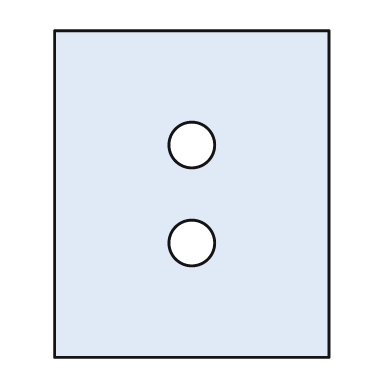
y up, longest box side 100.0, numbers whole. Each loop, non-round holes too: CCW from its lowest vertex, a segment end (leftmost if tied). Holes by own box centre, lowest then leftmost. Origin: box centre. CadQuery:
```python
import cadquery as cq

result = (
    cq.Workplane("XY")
    .moveTo(-42.0, -50.0)
    .lineTo(42.0, -50.0)
    .lineTo(42.0, 50.0)
    .lineTo(-42.0, 50.0)
    .close()
    .moveTo(0.0, -15.0)
    .circle(7.0)
    .moveTo(0.0, 15.0)
    .circle(7.0)
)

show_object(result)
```